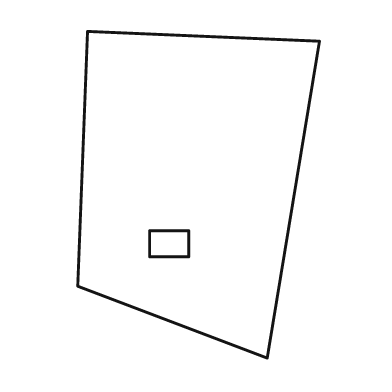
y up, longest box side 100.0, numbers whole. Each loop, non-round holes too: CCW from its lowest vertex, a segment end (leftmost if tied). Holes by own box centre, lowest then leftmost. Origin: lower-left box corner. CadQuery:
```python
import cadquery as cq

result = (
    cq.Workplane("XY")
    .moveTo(58.0, 0.0)
    .lineTo(74.0, 97.0)
    .lineTo(3.0, 100.0)
    .lineTo(0.0, 22.0)
    .close()
    .moveTo(22.0, 31.0)
    .lineTo(34.0, 31.0)
    .lineTo(34.0, 39.0)
    .lineTo(22.0, 39.0)
    .close()
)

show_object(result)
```